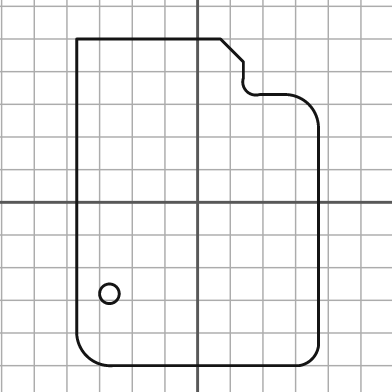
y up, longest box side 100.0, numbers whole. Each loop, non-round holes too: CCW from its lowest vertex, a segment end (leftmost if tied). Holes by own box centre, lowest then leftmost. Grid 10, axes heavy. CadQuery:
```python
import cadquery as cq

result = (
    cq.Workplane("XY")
    .moveTo(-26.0, -50.0)
    .lineTo(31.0, -50.0)
    .threePointArc((35.0, -48.0), (37.0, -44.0))
    .lineTo(37.0, 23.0)
    .threePointArc((34.0, 30.0), (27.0, 33.0))
    .lineTo(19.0, 33.0)
    .threePointArc((15.0, 34.0), (14.0, 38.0))
    .lineTo(14.0, 43.0)
    .lineTo(7.0, 50.0)
    .lineTo(-37.0, 50.0)
    .lineTo(-37.0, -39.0)
    .threePointArc((-34.0, -47.0), (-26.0, -50.0))
    .close()
    .moveTo(-27.0, -28.0)
    .circle(3.0)
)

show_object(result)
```